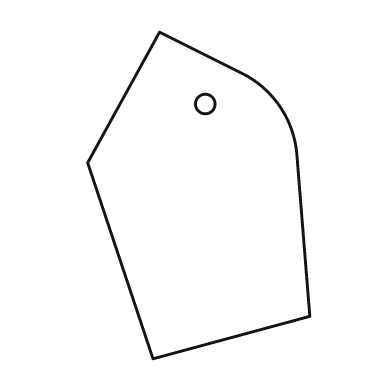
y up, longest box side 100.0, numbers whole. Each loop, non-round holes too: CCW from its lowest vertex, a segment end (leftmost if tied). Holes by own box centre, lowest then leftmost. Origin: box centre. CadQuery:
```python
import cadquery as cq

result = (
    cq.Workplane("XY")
    .moveTo(-14.0, -50.0)
    .lineTo(34.0, -37.0)
    .lineTo(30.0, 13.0)
    .threePointArc((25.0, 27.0), (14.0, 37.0))
    .lineTo(-12.0, 50.0)
    .lineTo(-34.0, 10.0)
    .close()
    .moveTo(2.0, 28.0)
    .circle(3.0)
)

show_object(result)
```